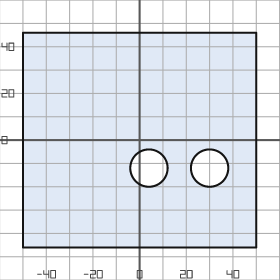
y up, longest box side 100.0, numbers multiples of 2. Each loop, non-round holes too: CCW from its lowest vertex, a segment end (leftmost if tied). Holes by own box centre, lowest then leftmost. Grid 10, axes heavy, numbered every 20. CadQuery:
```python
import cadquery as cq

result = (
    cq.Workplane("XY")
    .moveTo(-50.0, -46.0)
    .lineTo(50.0, -46.0)
    .lineTo(50.0, 46.0)
    .lineTo(-50.0, 46.0)
    .close()
    .moveTo(4.0, -12.0)
    .circle(8.0)
    .moveTo(30.0, -12.0)
    .circle(8.0)
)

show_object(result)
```